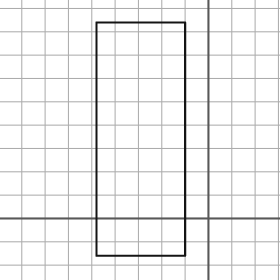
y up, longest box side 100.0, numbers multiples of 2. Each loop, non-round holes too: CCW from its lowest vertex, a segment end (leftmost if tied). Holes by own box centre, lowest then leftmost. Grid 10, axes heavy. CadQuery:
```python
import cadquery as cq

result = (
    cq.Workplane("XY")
    .moveTo(-48.0, -16.0)
    .lineTo(-10.0, -16.0)
    .lineTo(-10.0, 84.0)
    .lineTo(-48.0, 84.0)
    .close()
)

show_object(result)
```